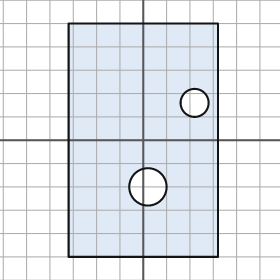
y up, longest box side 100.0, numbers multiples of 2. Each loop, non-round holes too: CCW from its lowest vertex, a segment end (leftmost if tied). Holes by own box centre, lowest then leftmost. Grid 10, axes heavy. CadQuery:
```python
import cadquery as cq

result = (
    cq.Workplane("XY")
    .moveTo(-32.0, -50.0)
    .lineTo(32.0, -50.0)
    .lineTo(32.0, 50.0)
    .lineTo(-32.0, 50.0)
    .close()
    .moveTo(2.0, -20.0)
    .circle(8.0)
    .moveTo(22.0, 16.0)
    .circle(6.0)
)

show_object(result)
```